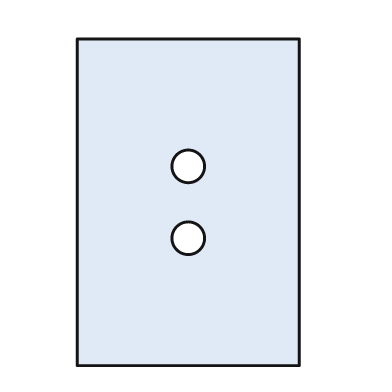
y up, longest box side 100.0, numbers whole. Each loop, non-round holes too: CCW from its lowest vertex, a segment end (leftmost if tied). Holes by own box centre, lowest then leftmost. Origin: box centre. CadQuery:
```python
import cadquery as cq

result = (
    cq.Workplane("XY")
    .moveTo(-34.0, -50.0)
    .lineTo(34.0, -50.0)
    .lineTo(34.0, 50.0)
    .lineTo(-34.0, 50.0)
    .close()
    .moveTo(0.0, -11.0)
    .circle(5.0)
    .moveTo(0.0, 11.0)
    .circle(5.0)
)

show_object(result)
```